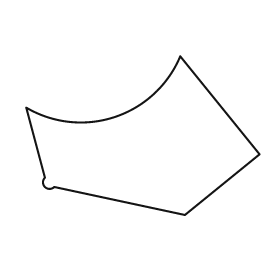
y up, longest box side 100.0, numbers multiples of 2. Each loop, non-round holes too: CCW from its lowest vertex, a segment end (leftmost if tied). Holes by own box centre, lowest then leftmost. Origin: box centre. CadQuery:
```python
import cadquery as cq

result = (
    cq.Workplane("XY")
    .moveTo(18.0, -34.0)
    .lineTo(50.0, -8.0)
    .lineTo(16.0, 34.0)
    .threePointArc((-12.0, 8.0), (-50.0, 12.0))
    .lineTo(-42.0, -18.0)
    .threePointArc((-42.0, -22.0), (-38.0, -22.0))
    .close()
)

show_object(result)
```